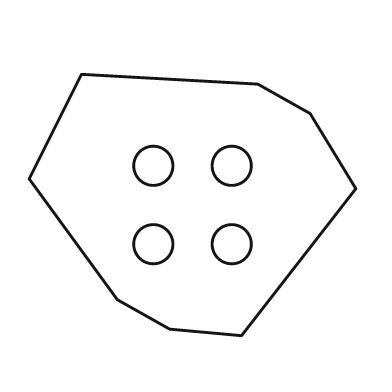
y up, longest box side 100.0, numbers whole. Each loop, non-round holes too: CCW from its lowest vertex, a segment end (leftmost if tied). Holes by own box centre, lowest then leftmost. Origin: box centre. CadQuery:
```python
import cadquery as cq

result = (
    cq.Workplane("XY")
    .moveTo(15.0, -40.0)
    .lineTo(50.0, 5.0)
    .lineTo(36.0, 28.0)
    .lineTo(20.0, 37.0)
    .lineTo(-34.0, 40.0)
    .lineTo(-50.0, 8.0)
    .lineTo(-23.0, -29.0)
    .lineTo(-7.0, -38.0)
    .close()
    .moveTo(-12.0, -12.0)
    .circle(6.0)
    .moveTo(12.0, -12.0)
    .circle(6.0)
    .moveTo(-12.0, 12.0)
    .circle(6.0)
    .moveTo(12.0, 12.0)
    .circle(6.0)
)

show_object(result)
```